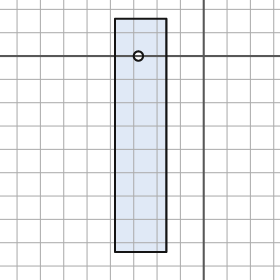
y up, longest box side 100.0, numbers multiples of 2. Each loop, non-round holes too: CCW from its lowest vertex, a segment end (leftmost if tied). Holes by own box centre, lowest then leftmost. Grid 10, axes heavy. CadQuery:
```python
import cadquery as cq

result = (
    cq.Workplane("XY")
    .moveTo(-38.0, -84.0)
    .lineTo(-16.0, -84.0)
    .lineTo(-16.0, 16.0)
    .lineTo(-38.0, 16.0)
    .close()
    .moveTo(-28.0, 0.0)
    .circle(2.0)
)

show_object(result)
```